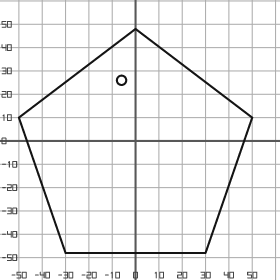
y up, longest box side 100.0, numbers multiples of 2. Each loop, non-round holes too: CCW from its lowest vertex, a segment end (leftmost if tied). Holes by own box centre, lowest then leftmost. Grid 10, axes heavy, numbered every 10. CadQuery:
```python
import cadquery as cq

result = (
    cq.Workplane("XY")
    .moveTo(-30.0, -48.0)
    .lineTo(30.0, -48.0)
    .lineTo(50.0, 10.0)
    .lineTo(0.0, 48.0)
    .lineTo(-50.0, 10.0)
    .close()
    .moveTo(-6.0, 26.0)
    .circle(2.0)
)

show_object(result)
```